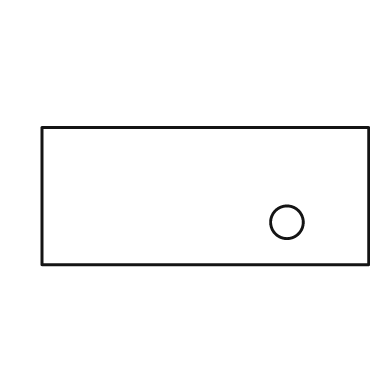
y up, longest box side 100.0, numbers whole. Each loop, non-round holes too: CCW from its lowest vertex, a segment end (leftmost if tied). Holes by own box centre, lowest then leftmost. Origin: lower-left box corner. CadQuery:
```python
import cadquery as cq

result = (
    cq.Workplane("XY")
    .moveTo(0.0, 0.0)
    .lineTo(100.0, 0.0)
    .lineTo(100.0, 42.0)
    .lineTo(0.0, 42.0)
    .close()
    .moveTo(75.0, 13.0)
    .circle(5.0)
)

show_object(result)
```